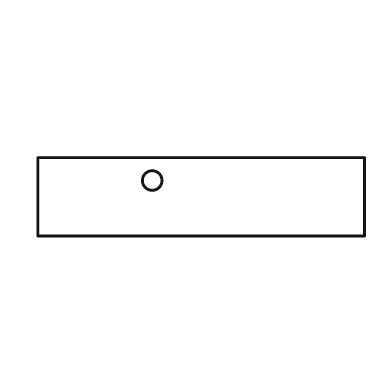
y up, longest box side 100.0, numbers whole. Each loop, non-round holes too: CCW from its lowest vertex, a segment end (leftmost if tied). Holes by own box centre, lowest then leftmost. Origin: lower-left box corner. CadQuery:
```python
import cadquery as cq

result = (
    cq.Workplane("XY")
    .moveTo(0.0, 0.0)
    .lineTo(100.0, 0.0)
    .lineTo(100.0, 24.0)
    .lineTo(0.0, 24.0)
    .close()
    .moveTo(35.0, 17.0)
    .circle(3.0)
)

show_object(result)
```